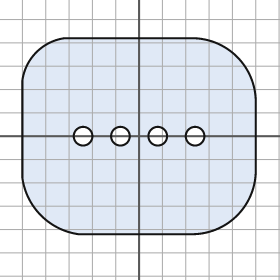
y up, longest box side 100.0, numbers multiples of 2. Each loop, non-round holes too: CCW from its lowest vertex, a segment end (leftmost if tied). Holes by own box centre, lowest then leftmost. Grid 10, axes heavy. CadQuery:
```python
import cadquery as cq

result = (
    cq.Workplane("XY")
    .moveTo(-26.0, -42.0)
    .lineTo(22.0, -42.0)
    .threePointArc((42.0, -34.0), (50.0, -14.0))
    .lineTo(50.0, 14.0)
    .threePointArc((42.0, 34.0), (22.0, 42.0))
    .lineTo(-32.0, 42.0)
    .threePointArc((-44.0, 36.0), (-50.0, 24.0))
    .lineTo(-50.0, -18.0)
    .threePointArc((-42.0, -34.0), (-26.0, -42.0))
    .close()
    .moveTo(-24.0, 0.0)
    .circle(4.0)
    .moveTo(-8.0, 0.0)
    .circle(4.0)
    .moveTo(8.0, 0.0)
    .circle(4.0)
    .moveTo(24.0, 0.0)
    .circle(4.0)
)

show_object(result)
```